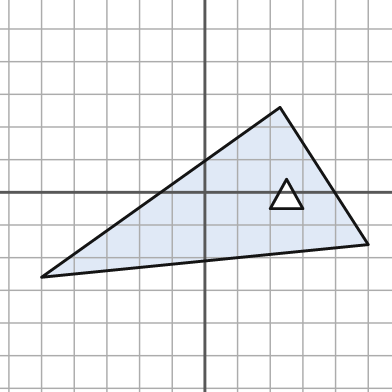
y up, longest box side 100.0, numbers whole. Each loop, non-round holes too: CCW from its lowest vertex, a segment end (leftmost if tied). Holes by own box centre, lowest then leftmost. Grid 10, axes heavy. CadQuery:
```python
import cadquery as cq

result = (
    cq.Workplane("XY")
    .moveTo(-50.0, -26.0)
    .lineTo(50.0, -16.0)
    .lineTo(23.0, 26.0)
    .close()
    .moveTo(20.0, -5.0)
    .lineTo(30.0, -5.0)
    .lineTo(25.0, 4.0)
    .close()
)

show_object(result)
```